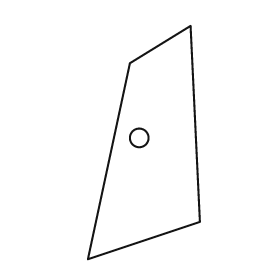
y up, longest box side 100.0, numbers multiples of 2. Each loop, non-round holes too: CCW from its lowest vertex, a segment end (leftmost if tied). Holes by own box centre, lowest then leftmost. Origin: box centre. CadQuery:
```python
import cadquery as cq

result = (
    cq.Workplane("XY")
    .moveTo(-24.0, -50.0)
    .lineTo(24.0, -34.0)
    .lineTo(20.0, 50.0)
    .lineTo(-6.0, 34.0)
    .close()
    .moveTo(-2.0, 2.0)
    .circle(4.0)
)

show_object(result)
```